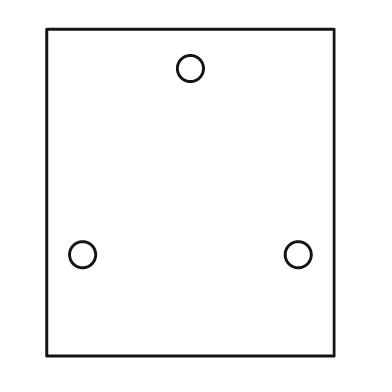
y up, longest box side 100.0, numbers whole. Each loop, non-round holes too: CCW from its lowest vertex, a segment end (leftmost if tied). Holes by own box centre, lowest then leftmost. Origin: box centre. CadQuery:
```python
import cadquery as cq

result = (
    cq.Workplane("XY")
    .moveTo(-44.0, -50.0)
    .lineTo(44.0, -50.0)
    .lineTo(44.0, 50.0)
    .lineTo(-44.0, 50.0)
    .close()
    .moveTo(-33.0, -19.0)
    .circle(4.0)
    .moveTo(33.0, -19.0)
    .circle(4.0)
    .moveTo(0.0, 38.0)
    .circle(4.0)
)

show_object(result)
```